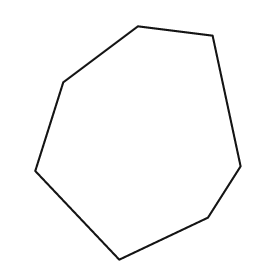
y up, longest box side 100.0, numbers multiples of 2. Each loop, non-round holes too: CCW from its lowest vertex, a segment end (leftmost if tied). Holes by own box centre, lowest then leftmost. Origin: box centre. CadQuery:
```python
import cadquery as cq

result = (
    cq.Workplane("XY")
    .moveTo(-8.0, -50.0)
    .lineTo(30.0, -32.0)
    .lineTo(44.0, -10.0)
    .lineTo(32.0, 46.0)
    .lineTo(0.0, 50.0)
    .lineTo(-32.0, 26.0)
    .lineTo(-44.0, -12.0)
    .close()
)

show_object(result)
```